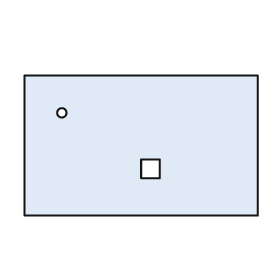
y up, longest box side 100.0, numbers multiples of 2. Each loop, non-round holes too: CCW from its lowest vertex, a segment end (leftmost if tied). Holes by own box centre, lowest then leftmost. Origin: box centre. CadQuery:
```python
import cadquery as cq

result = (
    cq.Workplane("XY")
    .moveTo(-50.0, -30.0)
    .lineTo(50.0, -30.0)
    .lineTo(50.0, 30.0)
    .lineTo(-50.0, 30.0)
    .close()
    .moveTo(0.0, -14.0)
    .lineTo(8.0, -14.0)
    .lineTo(8.0, -6.0)
    .lineTo(0.0, -6.0)
    .close()
    .moveTo(-34.0, 14.0)
    .circle(2.0)
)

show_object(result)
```